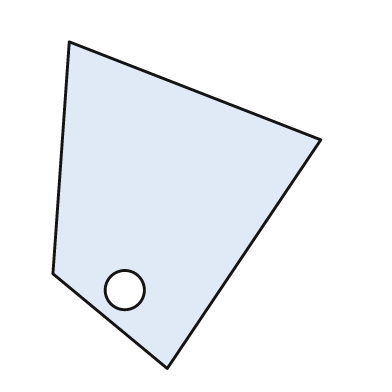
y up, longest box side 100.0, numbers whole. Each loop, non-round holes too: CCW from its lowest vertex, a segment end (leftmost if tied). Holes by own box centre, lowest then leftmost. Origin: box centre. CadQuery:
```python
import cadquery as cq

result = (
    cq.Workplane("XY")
    .moveTo(-6.0, -50.0)
    .lineTo(41.0, 20.0)
    .lineTo(-36.0, 50.0)
    .lineTo(-41.0, -21.0)
    .close()
    .moveTo(-19.0, -26.0)
    .circle(6.0)
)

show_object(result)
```